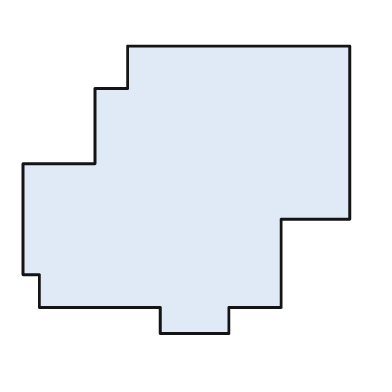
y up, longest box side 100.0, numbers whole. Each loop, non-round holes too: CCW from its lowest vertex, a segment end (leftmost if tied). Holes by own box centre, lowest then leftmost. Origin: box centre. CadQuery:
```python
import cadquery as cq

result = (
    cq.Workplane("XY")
    .moveTo(-8.0, -44.0)
    .lineTo(13.0, -44.0)
    .lineTo(13.0, -36.0)
    .lineTo(29.0, -36.0)
    .lineTo(29.0, -9.0)
    .lineTo(50.0, -9.0)
    .lineTo(50.0, 44.0)
    .lineTo(-18.0, 44.0)
    .lineTo(-18.0, 31.0)
    .lineTo(-28.0, 31.0)
    .lineTo(-28.0, 8.0)
    .lineTo(-50.0, 8.0)
    .lineTo(-50.0, -26.0)
    .lineTo(-45.0, -26.0)
    .lineTo(-45.0, -36.0)
    .lineTo(-8.0, -36.0)
    .close()
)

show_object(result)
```